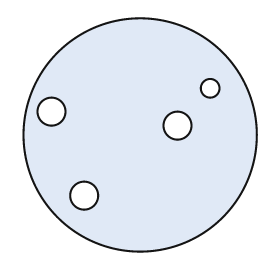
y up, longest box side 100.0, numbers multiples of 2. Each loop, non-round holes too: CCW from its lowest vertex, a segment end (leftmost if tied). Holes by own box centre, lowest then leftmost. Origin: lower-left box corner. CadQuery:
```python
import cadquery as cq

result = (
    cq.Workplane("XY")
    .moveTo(50.0, 50.0)
    .circle(50.0)
    .moveTo(26.0, 24.0)
    .circle(6.0)
    .moveTo(66.0, 54.0)
    .circle(6.0)
    .moveTo(12.0, 60.0)
    .circle(6.0)
    .moveTo(80.0, 70.0)
    .circle(4.0)
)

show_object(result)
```